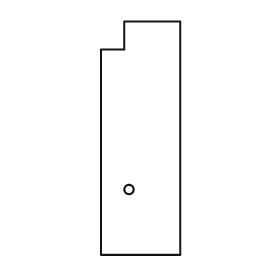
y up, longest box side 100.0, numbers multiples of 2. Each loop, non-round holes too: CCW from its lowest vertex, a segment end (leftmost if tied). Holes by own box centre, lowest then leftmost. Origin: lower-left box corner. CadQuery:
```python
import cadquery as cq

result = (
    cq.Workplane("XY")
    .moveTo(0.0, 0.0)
    .lineTo(34.0, 0.0)
    .lineTo(34.0, 100.0)
    .lineTo(10.0, 100.0)
    .lineTo(10.0, 88.0)
    .lineTo(0.0, 88.0)
    .close()
    .moveTo(12.0, 28.0)
    .circle(2.0)
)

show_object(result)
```